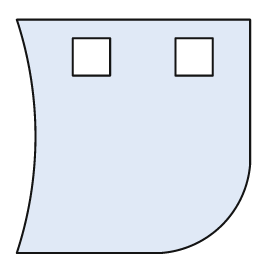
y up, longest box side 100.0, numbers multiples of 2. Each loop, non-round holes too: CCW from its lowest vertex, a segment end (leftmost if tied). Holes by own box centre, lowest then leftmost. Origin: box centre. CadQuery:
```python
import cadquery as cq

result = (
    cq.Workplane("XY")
    .moveTo(-50.0, -50.0)
    .lineTo(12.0, -50.0)
    .threePointArc((38.0, -38.0), (50.0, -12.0))
    .lineTo(50.0, 50.0)
    .lineTo(-50.0, 50.0)
    .threePointArc((-42.0, 0.0), (-50.0, -50.0))
    .close()
    .moveTo(-26.0, 26.0)
    .lineTo(-10.0, 26.0)
    .lineTo(-10.0, 42.0)
    .lineTo(-26.0, 42.0)
    .close()
    .moveTo(18.0, 26.0)
    .lineTo(34.0, 26.0)
    .lineTo(34.0, 42.0)
    .lineTo(18.0, 42.0)
    .close()
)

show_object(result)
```